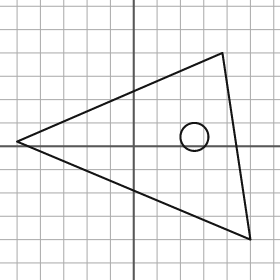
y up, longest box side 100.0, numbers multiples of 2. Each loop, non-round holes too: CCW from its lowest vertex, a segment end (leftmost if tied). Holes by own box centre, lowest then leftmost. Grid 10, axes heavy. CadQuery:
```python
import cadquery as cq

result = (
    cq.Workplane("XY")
    .moveTo(50.0, -40.0)
    .lineTo(38.0, 40.0)
    .lineTo(-50.0, 2.0)
    .close()
    .moveTo(26.0, 4.0)
    .circle(6.0)
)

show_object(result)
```